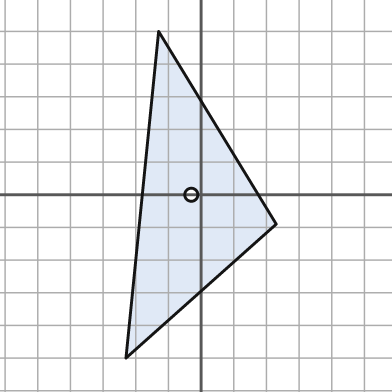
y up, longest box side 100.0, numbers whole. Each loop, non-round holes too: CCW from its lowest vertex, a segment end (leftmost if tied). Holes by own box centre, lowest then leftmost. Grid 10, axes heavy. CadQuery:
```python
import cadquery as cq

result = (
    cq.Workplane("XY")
    .moveTo(-23.0, -50.0)
    .lineTo(23.0, -9.0)
    .lineTo(-13.0, 50.0)
    .close()
    .moveTo(-3.0, 0.0)
    .circle(2.0)
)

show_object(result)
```